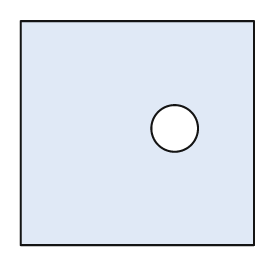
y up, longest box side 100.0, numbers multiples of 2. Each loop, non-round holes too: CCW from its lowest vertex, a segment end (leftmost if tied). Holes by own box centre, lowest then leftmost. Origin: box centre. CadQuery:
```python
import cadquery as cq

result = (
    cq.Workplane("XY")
    .moveTo(-50.0, -48.0)
    .lineTo(50.0, -48.0)
    .lineTo(50.0, 48.0)
    .lineTo(-50.0, 48.0)
    .close()
    .moveTo(16.0, 2.0)
    .circle(10.0)
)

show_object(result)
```